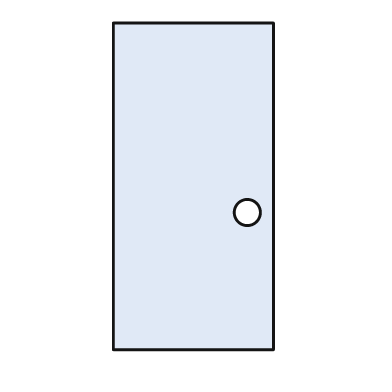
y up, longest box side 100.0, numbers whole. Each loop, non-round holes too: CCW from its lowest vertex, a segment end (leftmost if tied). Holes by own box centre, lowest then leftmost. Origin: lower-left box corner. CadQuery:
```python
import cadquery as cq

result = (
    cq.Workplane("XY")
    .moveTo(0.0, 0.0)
    .lineTo(49.0, 0.0)
    .lineTo(49.0, 100.0)
    .lineTo(0.0, 100.0)
    .close()
    .moveTo(41.0, 42.0)
    .circle(4.0)
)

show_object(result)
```